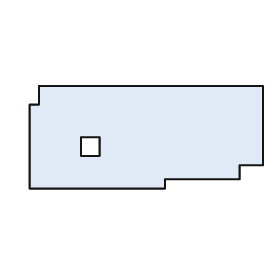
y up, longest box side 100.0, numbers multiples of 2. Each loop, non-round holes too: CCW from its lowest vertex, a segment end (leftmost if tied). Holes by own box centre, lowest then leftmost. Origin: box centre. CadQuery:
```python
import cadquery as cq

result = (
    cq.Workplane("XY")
    .moveTo(-50.0, -22.0)
    .lineTo(8.0, -22.0)
    .lineTo(8.0, -18.0)
    .lineTo(40.0, -18.0)
    .lineTo(40.0, -12.0)
    .lineTo(50.0, -12.0)
    .lineTo(50.0, 22.0)
    .lineTo(-46.0, 22.0)
    .lineTo(-46.0, 14.0)
    .lineTo(-50.0, 14.0)
    .close()
    .moveTo(-28.0, -8.0)
    .lineTo(-20.0, -8.0)
    .lineTo(-20.0, 0.0)
    .lineTo(-28.0, 0.0)
    .close()
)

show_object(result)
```